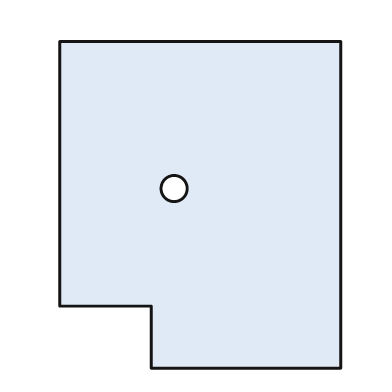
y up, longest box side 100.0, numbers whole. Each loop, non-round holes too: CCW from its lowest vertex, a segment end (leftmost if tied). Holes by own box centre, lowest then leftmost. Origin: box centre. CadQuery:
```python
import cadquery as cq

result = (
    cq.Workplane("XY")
    .moveTo(-15.0, -50.0)
    .lineTo(43.0, -50.0)
    .lineTo(43.0, 50.0)
    .lineTo(-43.0, 50.0)
    .lineTo(-43.0, -31.0)
    .lineTo(-15.0, -31.0)
    .close()
    .moveTo(-8.0, 5.0)
    .circle(4.0)
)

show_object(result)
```